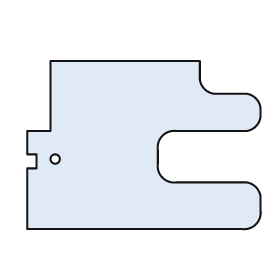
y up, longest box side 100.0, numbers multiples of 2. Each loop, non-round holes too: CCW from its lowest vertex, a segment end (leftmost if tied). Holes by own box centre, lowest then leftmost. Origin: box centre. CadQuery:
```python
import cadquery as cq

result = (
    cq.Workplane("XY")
    .moveTo(-50.0, -36.0)
    .lineTo(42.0, -36.0)
    .threePointArc((48.0, -34.0), (50.0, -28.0))
    .lineTo(50.0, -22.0)
    .threePointArc((48.0, -18.0), (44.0, -16.0))
    .lineTo(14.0, -16.0)
    .threePointArc((8.0, -14.0), (6.0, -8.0))
    .lineTo(6.0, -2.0)
    .threePointArc((8.0, 4.0), (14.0, 6.0))
    .lineTo(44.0, 6.0)
    .threePointArc((48.0, 8.0), (50.0, 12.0))
    .lineTo(50.0, 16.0)
    .threePointArc((48.0, 20.0), (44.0, 22.0))
    .lineTo(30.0, 22.0)
    .threePointArc((26.0, 24.0), (24.0, 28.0))
    .lineTo(24.0, 36.0)
    .lineTo(-40.0, 36.0)
    .lineTo(-40.0, 6.0)
    .lineTo(-50.0, 6.0)
    .lineTo(-50.0, -4.0)
    .lineTo(-46.0, -4.0)
    .lineTo(-46.0, -10.0)
    .lineTo(-50.0, -10.0)
    .close()
    .moveTo(-38.0, -6.0)
    .circle(2.0)
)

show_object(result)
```